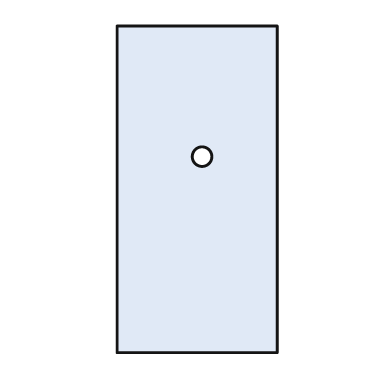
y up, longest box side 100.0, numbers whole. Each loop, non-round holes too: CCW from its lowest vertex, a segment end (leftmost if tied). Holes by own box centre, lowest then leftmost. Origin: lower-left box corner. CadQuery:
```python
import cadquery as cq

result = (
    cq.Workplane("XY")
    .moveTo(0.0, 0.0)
    .lineTo(49.0, 0.0)
    .lineTo(49.0, 100.0)
    .lineTo(0.0, 100.0)
    .close()
    .moveTo(26.0, 60.0)
    .circle(3.0)
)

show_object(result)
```